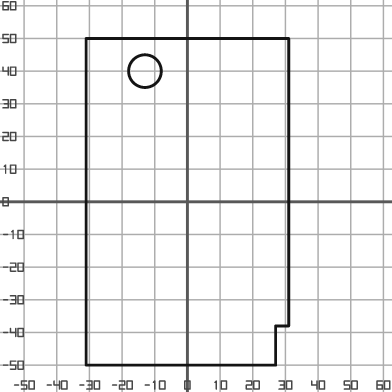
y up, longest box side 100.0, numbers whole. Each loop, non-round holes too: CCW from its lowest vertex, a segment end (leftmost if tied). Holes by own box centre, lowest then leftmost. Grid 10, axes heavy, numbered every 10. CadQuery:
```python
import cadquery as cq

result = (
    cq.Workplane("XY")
    .moveTo(-31.0, -50.0)
    .lineTo(27.0, -50.0)
    .lineTo(27.0, -38.0)
    .lineTo(31.0, -38.0)
    .lineTo(31.0, 50.0)
    .lineTo(-31.0, 50.0)
    .close()
    .moveTo(-13.0, 40.0)
    .circle(5.0)
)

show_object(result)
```